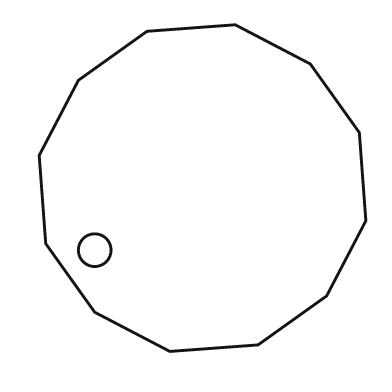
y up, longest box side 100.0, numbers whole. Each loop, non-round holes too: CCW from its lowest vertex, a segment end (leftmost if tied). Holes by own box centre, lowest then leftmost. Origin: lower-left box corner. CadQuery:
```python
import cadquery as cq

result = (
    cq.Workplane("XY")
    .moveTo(40.0, 0.0)
    .lineTo(67.0, 2.0)
    .lineTo(88.0, 17.0)
    .lineTo(100.0, 40.0)
    .lineTo(98.0, 67.0)
    .lineTo(83.0, 88.0)
    .lineTo(60.0, 100.0)
    .lineTo(33.0, 98.0)
    .lineTo(12.0, 83.0)
    .lineTo(0.0, 60.0)
    .lineTo(2.0, 33.0)
    .lineTo(17.0, 12.0)
    .close()
    .moveTo(17.0, 31.0)
    .circle(5.0)
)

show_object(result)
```